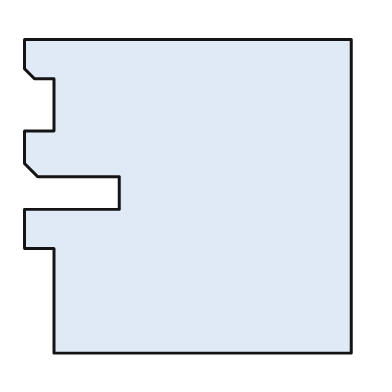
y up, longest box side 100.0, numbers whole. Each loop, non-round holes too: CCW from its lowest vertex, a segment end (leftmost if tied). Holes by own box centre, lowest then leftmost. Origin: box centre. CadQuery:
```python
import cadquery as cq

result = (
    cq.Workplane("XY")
    .moveTo(-41.0, -48.0)
    .lineTo(50.0, -48.0)
    .lineTo(50.0, 48.0)
    .lineTo(-50.0, 48.0)
    .lineTo(-50.0, 39.0)
    .lineTo(-47.0, 36.0)
    .lineTo(-41.0, 36.0)
    .lineTo(-41.0, 20.0)
    .lineTo(-50.0, 20.0)
    .lineTo(-50.0, 10.0)
    .lineTo(-46.0, 6.0)
    .lineTo(-21.0, 6.0)
    .lineTo(-21.0, -4.0)
    .lineTo(-50.0, -4.0)
    .lineTo(-50.0, -16.0)
    .lineTo(-41.0, -16.0)
    .close()
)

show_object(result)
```